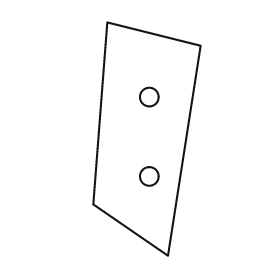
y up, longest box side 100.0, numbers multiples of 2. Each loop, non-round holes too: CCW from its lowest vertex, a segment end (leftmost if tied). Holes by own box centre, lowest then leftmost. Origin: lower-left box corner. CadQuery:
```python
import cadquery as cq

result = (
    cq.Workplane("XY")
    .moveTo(32.0, 0.0)
    .lineTo(46.0, 90.0)
    .lineTo(6.0, 100.0)
    .lineTo(0.0, 22.0)
    .close()
    .moveTo(24.0, 34.0)
    .circle(4.0)
    .moveTo(24.0, 68.0)
    .circle(4.0)
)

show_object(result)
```